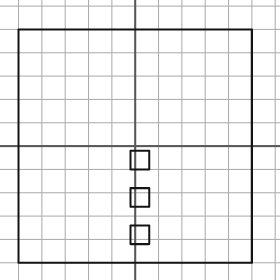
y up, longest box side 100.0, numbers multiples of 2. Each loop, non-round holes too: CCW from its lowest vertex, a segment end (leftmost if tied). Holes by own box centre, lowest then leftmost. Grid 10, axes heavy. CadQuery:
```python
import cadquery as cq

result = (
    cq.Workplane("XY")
    .moveTo(-50.0, -50.0)
    .lineTo(50.0, -50.0)
    .lineTo(50.0, 50.0)
    .lineTo(-50.0, 50.0)
    .close()
    .moveTo(-2.0, -42.0)
    .lineTo(6.0, -42.0)
    .lineTo(6.0, -34.0)
    .lineTo(-2.0, -34.0)
    .close()
    .moveTo(-2.0, -26.0)
    .lineTo(6.0, -26.0)
    .lineTo(6.0, -18.0)
    .lineTo(-2.0, -18.0)
    .close()
    .moveTo(-2.0, -10.0)
    .lineTo(6.0, -10.0)
    .lineTo(6.0, -2.0)
    .lineTo(-2.0, -2.0)
    .close()
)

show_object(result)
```